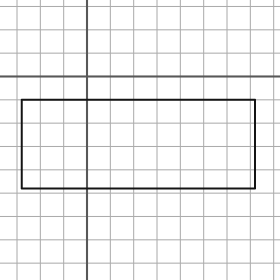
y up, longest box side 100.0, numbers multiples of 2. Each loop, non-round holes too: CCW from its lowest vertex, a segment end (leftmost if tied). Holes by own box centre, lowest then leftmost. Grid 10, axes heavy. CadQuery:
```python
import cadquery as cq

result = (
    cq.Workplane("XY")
    .moveTo(-28.0, -48.0)
    .lineTo(72.0, -48.0)
    .lineTo(72.0, -10.0)
    .lineTo(-28.0, -10.0)
    .close()
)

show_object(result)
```